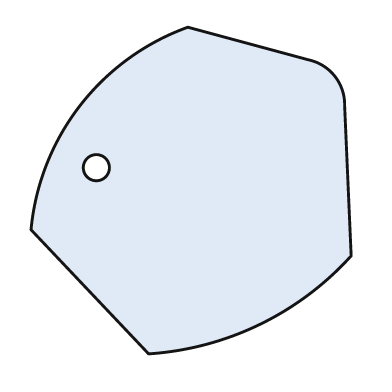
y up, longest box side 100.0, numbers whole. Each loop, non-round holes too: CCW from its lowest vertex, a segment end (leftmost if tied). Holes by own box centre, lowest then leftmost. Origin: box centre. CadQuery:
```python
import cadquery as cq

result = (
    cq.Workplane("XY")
    .moveTo(-13.0, -50.0)
    .threePointArc((21.0, -41.0), (49.0, -20.0))
    .lineTo(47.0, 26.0)
    .threePointArc((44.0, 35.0), (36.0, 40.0))
    .lineTo(-1.0, 50.0)
    .threePointArc((-34.0, 26.0), (-49.0, -12.0))
    .close()
    .moveTo(-29.0, 7.0)
    .circle(4.0)
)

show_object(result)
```